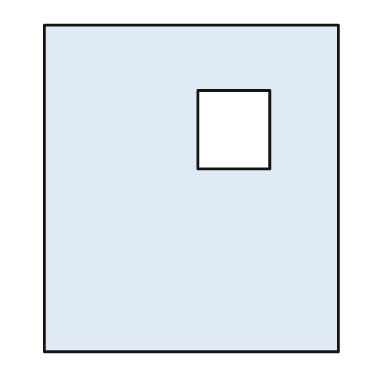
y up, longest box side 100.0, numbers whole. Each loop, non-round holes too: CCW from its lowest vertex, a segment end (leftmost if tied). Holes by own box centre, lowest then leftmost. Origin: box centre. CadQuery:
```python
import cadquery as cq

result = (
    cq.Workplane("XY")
    .moveTo(-45.0, -50.0)
    .lineTo(45.0, -50.0)
    .lineTo(45.0, 50.0)
    .lineTo(-45.0, 50.0)
    .close()
    .moveTo(2.0, 6.0)
    .lineTo(24.0, 6.0)
    .lineTo(24.0, 30.0)
    .lineTo(2.0, 30.0)
    .close()
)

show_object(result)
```